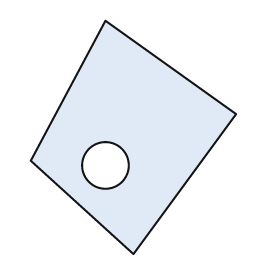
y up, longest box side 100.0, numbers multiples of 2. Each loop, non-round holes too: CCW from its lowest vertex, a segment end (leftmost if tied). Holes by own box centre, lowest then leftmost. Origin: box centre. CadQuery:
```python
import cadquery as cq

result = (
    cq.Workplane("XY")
    .moveTo(0.0, -50.0)
    .lineTo(44.0, 10.0)
    .lineTo(-12.0, 50.0)
    .lineTo(-44.0, -10.0)
    .close()
    .moveTo(-12.0, -12.0)
    .circle(10.0)
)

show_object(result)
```